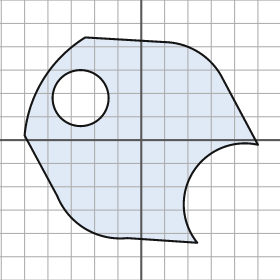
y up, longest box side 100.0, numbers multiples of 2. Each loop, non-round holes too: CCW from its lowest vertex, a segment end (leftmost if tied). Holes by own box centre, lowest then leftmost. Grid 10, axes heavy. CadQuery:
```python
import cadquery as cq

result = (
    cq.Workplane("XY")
    .moveTo(24.0, -44.0)
    .threePointArc((22.0, -14.0), (50.0, -2.0))
    .lineTo(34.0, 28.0)
    .threePointArc((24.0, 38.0), (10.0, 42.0))
    .lineTo(-24.0, 44.0)
    .threePointArc((-42.0, 26.0), (-50.0, 2.0))
    .lineTo(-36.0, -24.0)
    .threePointArc((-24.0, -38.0), (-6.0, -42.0))
    .close()
    .moveTo(-26.0, 18.0)
    .circle(12.0)
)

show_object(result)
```